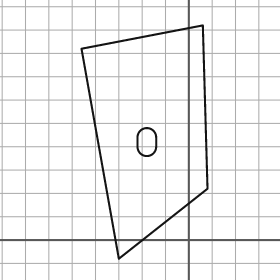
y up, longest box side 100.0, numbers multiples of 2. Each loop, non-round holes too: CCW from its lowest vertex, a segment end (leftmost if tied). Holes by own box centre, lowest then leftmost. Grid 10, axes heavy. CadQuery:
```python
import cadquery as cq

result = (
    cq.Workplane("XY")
    .moveTo(-30.0, -8.0)
    .lineTo(8.0, 22.0)
    .lineTo(6.0, 92.0)
    .lineTo(-46.0, 82.0)
    .close()
    .moveTo(-22.0, 40.0)
    .threePointArc((-18.0, 36.0), (-14.0, 40.0))
    .lineTo(-14.0, 44.0)
    .threePointArc((-18.0, 48.0), (-22.0, 44.0))
    .close()
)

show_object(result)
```